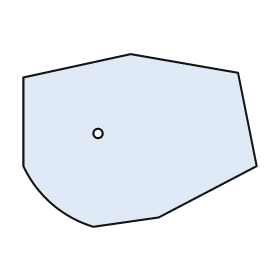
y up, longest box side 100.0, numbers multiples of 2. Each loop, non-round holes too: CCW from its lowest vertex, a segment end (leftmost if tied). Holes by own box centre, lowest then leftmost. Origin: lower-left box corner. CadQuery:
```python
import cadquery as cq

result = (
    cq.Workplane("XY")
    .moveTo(30.0, 0.0)
    .lineTo(58.0, 4.0)
    .lineTo(100.0, 26.0)
    .lineTo(92.0, 66.0)
    .lineTo(46.0, 74.0)
    .lineTo(0.0, 64.0)
    .lineTo(0.0, 26.0)
    .threePointArc((12.0, 10.0), (30.0, 0.0))
    .close()
    .moveTo(32.0, 40.0)
    .circle(2.0)
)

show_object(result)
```